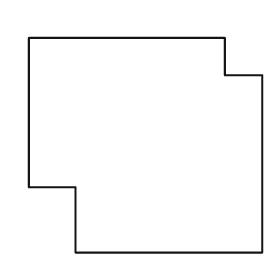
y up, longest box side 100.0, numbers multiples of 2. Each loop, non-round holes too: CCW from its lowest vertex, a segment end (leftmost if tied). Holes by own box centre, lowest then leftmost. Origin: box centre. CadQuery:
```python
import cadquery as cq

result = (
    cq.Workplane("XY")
    .moveTo(-30.0, -46.0)
    .lineTo(50.0, -46.0)
    .lineTo(50.0, 30.0)
    .lineTo(34.0, 30.0)
    .lineTo(34.0, 46.0)
    .lineTo(-50.0, 46.0)
    .lineTo(-50.0, -18.0)
    .lineTo(-30.0, -18.0)
    .close()
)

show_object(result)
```